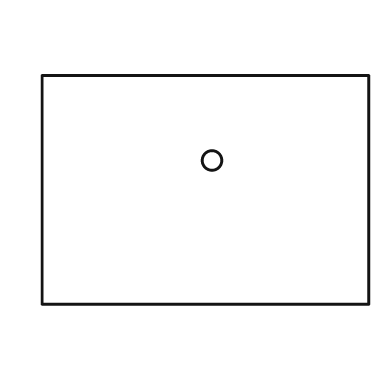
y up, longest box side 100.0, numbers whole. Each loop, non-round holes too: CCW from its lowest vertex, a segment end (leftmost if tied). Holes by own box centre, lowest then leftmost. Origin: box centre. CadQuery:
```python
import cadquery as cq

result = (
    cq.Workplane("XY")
    .moveTo(-50.0, -35.0)
    .lineTo(50.0, -35.0)
    .lineTo(50.0, 35.0)
    .lineTo(-50.0, 35.0)
    .close()
    .moveTo(2.0, 9.0)
    .circle(3.0)
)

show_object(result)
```